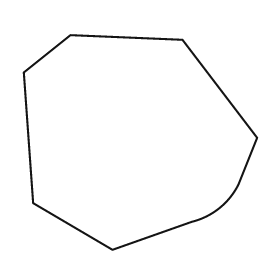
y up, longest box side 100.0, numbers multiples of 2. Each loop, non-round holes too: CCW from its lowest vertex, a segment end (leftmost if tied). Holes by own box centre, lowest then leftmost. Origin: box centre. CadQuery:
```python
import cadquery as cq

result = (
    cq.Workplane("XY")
    .moveTo(-12.0, -46.0)
    .lineTo(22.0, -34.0)
    .threePointArc((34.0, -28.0), (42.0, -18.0))
    .lineTo(50.0, 2.0)
    .lineTo(18.0, 44.0)
    .lineTo(-30.0, 46.0)
    .lineTo(-50.0, 30.0)
    .lineTo(-46.0, -26.0)
    .close()
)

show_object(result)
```